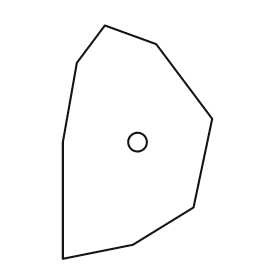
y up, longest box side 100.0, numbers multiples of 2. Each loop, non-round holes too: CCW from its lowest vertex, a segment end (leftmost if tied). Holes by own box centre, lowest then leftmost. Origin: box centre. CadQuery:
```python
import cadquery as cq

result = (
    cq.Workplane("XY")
    .moveTo(-32.0, -50.0)
    .lineTo(-2.0, -44.0)
    .lineTo(24.0, -28.0)
    .lineTo(32.0, 10.0)
    .lineTo(8.0, 42.0)
    .lineTo(-14.0, 50.0)
    .lineTo(-26.0, 34.0)
    .lineTo(-32.0, 0.0)
    .close()
    .moveTo(0.0, 0.0)
    .circle(4.0)
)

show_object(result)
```